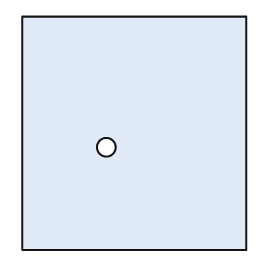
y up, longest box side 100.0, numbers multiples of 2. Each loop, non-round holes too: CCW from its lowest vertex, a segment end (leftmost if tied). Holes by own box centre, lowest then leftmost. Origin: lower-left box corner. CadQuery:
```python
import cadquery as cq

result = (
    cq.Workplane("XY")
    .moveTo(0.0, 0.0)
    .lineTo(96.0, 0.0)
    .lineTo(96.0, 100.0)
    .lineTo(0.0, 100.0)
    .close()
    .moveTo(36.0, 44.0)
    .circle(4.0)
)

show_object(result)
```